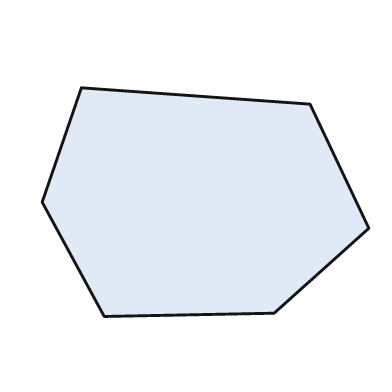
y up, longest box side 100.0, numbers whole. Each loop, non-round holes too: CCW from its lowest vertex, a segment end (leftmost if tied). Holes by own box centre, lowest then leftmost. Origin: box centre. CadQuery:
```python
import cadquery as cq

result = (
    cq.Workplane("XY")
    .moveTo(-31.0, -35.0)
    .lineTo(21.0, -34.0)
    .lineTo(50.0, -8.0)
    .lineTo(32.0, 30.0)
    .lineTo(-38.0, 35.0)
    .lineTo(-50.0, 0.0)
    .close()
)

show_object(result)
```